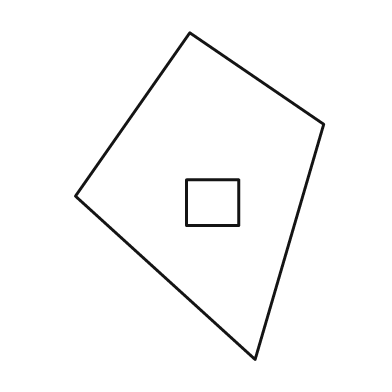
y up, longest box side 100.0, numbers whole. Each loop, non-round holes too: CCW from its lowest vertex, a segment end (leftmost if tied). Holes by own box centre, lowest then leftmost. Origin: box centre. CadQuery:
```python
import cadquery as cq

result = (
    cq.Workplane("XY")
    .moveTo(17.0, -50.0)
    .lineTo(38.0, 22.0)
    .lineTo(-3.0, 50.0)
    .lineTo(-38.0, 0.0)
    .close()
    .moveTo(-4.0, -9.0)
    .lineTo(12.0, -9.0)
    .lineTo(12.0, 5.0)
    .lineTo(-4.0, 5.0)
    .close()
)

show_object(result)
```